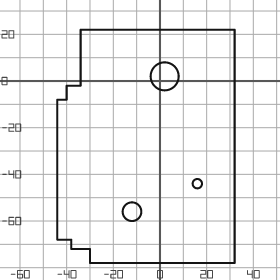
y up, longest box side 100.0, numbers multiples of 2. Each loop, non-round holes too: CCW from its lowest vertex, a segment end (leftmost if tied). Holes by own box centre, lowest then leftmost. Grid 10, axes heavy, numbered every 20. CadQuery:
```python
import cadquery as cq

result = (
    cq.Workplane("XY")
    .moveTo(-30.0, -78.0)
    .lineTo(32.0, -78.0)
    .lineTo(32.0, 22.0)
    .lineTo(-34.0, 22.0)
    .lineTo(-34.0, -2.0)
    .lineTo(-40.0, -2.0)
    .lineTo(-40.0, -8.0)
    .lineTo(-44.0, -8.0)
    .lineTo(-44.0, -68.0)
    .lineTo(-38.0, -68.0)
    .lineTo(-38.0, -72.0)
    .lineTo(-30.0, -72.0)
    .close()
    .moveTo(-12.0, -56.0)
    .circle(4.0)
    .moveTo(16.0, -44.0)
    .circle(2.0)
    .moveTo(2.0, 2.0)
    .circle(6.0)
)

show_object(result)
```